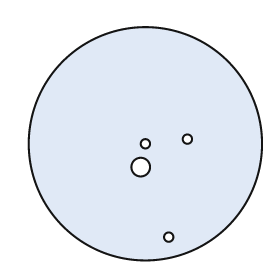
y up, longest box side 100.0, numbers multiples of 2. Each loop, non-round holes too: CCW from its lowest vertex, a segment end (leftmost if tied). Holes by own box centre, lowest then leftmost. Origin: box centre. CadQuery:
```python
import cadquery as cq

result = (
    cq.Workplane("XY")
    .moveTo(0.0, 0.0)
    .circle(50.0)
    .moveTo(10.0, -40.0)
    .circle(2.0)
    .moveTo(-2.0, -10.0)
    .circle(4.0)
    .moveTo(0.0, 0.0)
    .circle(2.0)
    .moveTo(18.0, 2.0)
    .circle(2.0)
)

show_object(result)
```